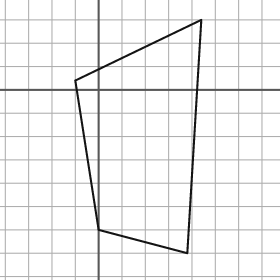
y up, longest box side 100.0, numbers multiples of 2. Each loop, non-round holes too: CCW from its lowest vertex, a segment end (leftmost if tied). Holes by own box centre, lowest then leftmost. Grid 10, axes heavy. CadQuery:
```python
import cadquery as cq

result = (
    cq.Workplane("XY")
    .moveTo(38.0, -70.0)
    .lineTo(44.0, 30.0)
    .lineTo(-10.0, 4.0)
    .lineTo(0.0, -60.0)
    .close()
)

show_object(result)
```